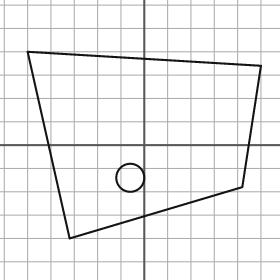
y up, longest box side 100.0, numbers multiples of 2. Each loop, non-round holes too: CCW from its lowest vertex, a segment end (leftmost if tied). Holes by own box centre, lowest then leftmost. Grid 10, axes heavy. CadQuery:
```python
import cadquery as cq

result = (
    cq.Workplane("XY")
    .moveTo(-32.0, -40.0)
    .lineTo(42.0, -18.0)
    .lineTo(50.0, 34.0)
    .lineTo(-50.0, 40.0)
    .close()
    .moveTo(-6.0, -14.0)
    .circle(6.0)
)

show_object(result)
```